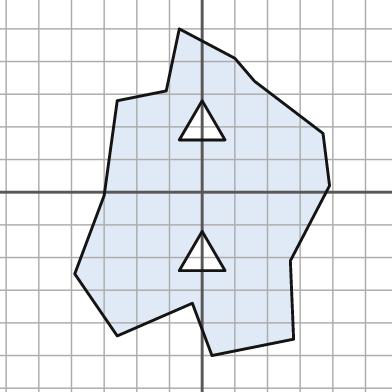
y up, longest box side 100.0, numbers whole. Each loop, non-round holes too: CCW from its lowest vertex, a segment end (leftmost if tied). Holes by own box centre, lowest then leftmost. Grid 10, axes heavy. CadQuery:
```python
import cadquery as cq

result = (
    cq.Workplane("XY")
    .moveTo(3.0, -50.0)
    .lineTo(28.0, -45.0)
    .lineTo(27.0, -21.0)
    .lineTo(39.0, 2.0)
    .lineTo(37.0, 18.0)
    .lineTo(16.0, 34.0)
    .lineTo(10.0, 41.0)
    .lineTo(-7.0, 50.0)
    .lineTo(-11.0, 31.0)
    .lineTo(-26.0, 28.0)
    .lineTo(-30.0, -1.0)
    .lineTo(-39.0, -25.0)
    .lineTo(-26.0, -44.0)
    .lineTo(-3.0, -34.0)
    .close()
    .moveTo(-7.0, -24.0)
    .lineTo(7.0, -24.0)
    .lineTo(0.0, -12.0)
    .close()
    .moveTo(-7.0, 16.0)
    .lineTo(7.0, 16.0)
    .lineTo(0.0, 28.0)
    .close()
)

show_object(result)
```